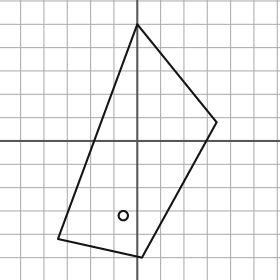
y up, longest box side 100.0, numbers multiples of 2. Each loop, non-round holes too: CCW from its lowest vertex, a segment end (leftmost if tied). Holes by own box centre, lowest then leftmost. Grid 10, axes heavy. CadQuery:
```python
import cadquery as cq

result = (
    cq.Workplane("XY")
    .moveTo(2.0, -50.0)
    .lineTo(34.0, 8.0)
    .lineTo(0.0, 50.0)
    .lineTo(-34.0, -42.0)
    .close()
    .moveTo(-6.0, -32.0)
    .circle(2.0)
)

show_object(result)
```